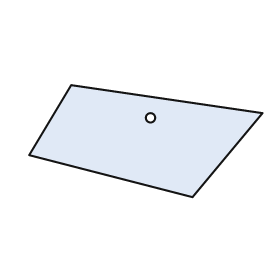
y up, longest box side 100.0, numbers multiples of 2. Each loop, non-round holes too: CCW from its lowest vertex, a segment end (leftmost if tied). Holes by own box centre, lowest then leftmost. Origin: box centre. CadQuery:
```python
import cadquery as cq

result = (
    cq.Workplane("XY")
    .moveTo(20.0, -24.0)
    .lineTo(50.0, 12.0)
    .lineTo(-32.0, 24.0)
    .lineTo(-50.0, -6.0)
    .close()
    .moveTo(2.0, 10.0)
    .circle(2.0)
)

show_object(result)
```